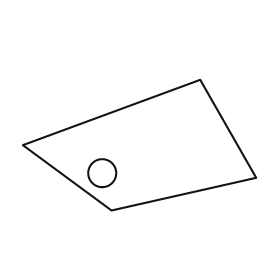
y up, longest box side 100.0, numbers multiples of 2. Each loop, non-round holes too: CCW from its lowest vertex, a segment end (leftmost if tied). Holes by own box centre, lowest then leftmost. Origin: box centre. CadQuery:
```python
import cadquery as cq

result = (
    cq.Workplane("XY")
    .moveTo(-12.0, -28.0)
    .lineTo(50.0, -14.0)
    .lineTo(26.0, 28.0)
    .lineTo(-50.0, 0.0)
    .close()
    .moveTo(-16.0, -12.0)
    .circle(6.0)
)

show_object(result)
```